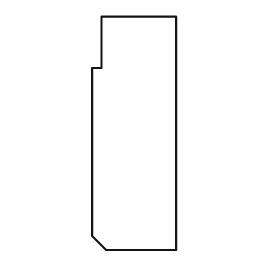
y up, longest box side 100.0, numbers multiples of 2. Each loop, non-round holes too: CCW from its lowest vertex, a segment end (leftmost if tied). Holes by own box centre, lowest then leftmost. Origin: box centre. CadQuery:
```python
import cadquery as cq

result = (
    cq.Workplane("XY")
    .moveTo(-12.0, -50.0)
    .lineTo(18.0, -50.0)
    .lineTo(18.0, 50.0)
    .lineTo(-14.0, 50.0)
    .lineTo(-14.0, 28.0)
    .lineTo(-18.0, 28.0)
    .lineTo(-18.0, -44.0)
    .close()
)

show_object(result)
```